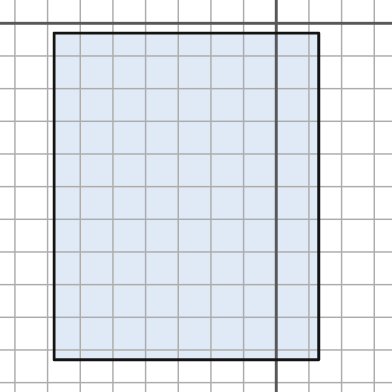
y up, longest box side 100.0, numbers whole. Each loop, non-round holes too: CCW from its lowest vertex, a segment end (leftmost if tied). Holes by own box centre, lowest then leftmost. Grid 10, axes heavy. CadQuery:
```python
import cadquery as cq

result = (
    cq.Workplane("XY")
    .moveTo(-68.0, -103.0)
    .lineTo(13.0, -103.0)
    .lineTo(13.0, -3.0)
    .lineTo(-68.0, -3.0)
    .close()
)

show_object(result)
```